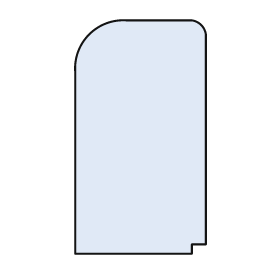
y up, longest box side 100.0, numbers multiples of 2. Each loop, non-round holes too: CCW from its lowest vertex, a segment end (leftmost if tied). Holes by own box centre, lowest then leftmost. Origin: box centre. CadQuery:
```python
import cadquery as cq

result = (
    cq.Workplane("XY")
    .moveTo(-28.0, -50.0)
    .lineTo(22.0, -50.0)
    .lineTo(22.0, -46.0)
    .lineTo(28.0, -46.0)
    .lineTo(28.0, 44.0)
    .threePointArc((26.0, 48.0), (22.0, 50.0))
    .lineTo(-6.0, 50.0)
    .threePointArc((-22.0, 44.0), (-28.0, 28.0))
    .close()
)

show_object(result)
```